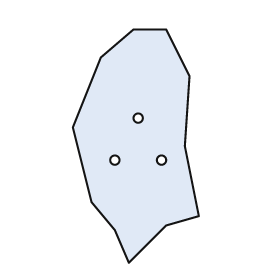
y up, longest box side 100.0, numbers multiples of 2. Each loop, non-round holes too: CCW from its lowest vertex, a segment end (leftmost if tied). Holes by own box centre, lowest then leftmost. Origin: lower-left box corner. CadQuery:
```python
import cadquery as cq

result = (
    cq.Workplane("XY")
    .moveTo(24.0, 0.0)
    .lineTo(40.0, 16.0)
    .lineTo(54.0, 20.0)
    .lineTo(48.0, 50.0)
    .lineTo(50.0, 80.0)
    .lineTo(40.0, 100.0)
    .lineTo(26.0, 100.0)
    .lineTo(12.0, 88.0)
    .lineTo(0.0, 58.0)
    .lineTo(8.0, 26.0)
    .lineTo(18.0, 14.0)
    .close()
    .moveTo(18.0, 44.0)
    .circle(2.0)
    .moveTo(38.0, 44.0)
    .circle(2.0)
    .moveTo(28.0, 62.0)
    .circle(2.0)
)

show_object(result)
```